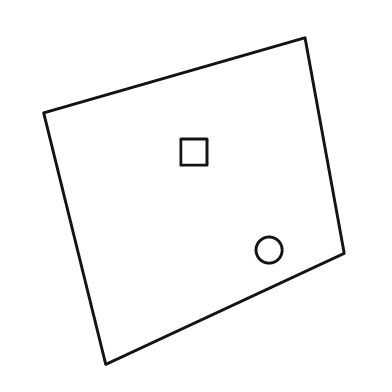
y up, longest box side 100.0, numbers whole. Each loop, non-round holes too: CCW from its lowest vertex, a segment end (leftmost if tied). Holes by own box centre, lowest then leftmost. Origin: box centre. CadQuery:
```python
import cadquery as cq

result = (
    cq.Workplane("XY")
    .moveTo(-27.0, -50.0)
    .lineTo(46.0, -16.0)
    .lineTo(34.0, 50.0)
    .lineTo(-46.0, 27.0)
    .close()
    .moveTo(23.0, -15.0)
    .circle(4.0)
    .moveTo(-4.0, 11.0)
    .lineTo(4.0, 11.0)
    .lineTo(4.0, 19.0)
    .lineTo(-4.0, 19.0)
    .close()
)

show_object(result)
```